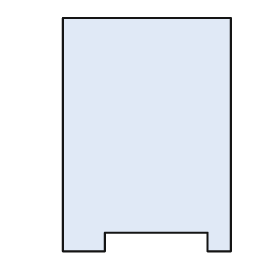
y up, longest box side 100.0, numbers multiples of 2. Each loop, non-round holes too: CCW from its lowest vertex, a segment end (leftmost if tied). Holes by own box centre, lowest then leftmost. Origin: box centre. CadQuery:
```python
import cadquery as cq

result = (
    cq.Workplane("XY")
    .moveTo(-36.0, -50.0)
    .lineTo(-18.0, -50.0)
    .lineTo(-18.0, -42.0)
    .lineTo(26.0, -42.0)
    .lineTo(26.0, -50.0)
    .lineTo(36.0, -50.0)
    .lineTo(36.0, 50.0)
    .lineTo(-36.0, 50.0)
    .close()
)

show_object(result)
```